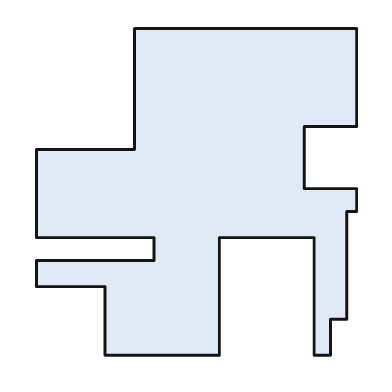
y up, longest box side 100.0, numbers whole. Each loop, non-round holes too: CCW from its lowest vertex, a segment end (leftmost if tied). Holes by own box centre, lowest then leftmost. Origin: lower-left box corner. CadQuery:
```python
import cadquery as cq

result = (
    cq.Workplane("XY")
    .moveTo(21.0, 0.0)
    .lineTo(56.0, 0.0)
    .lineTo(56.0, 36.0)
    .lineTo(85.0, 36.0)
    .lineTo(85.0, 0.0)
    .lineTo(90.0, 0.0)
    .lineTo(90.0, 11.0)
    .lineTo(95.0, 11.0)
    .lineTo(95.0, 44.0)
    .lineTo(98.0, 44.0)
    .lineTo(98.0, 51.0)
    .lineTo(82.0, 51.0)
    .lineTo(82.0, 70.0)
    .lineTo(98.0, 70.0)
    .lineTo(98.0, 100.0)
    .lineTo(30.0, 100.0)
    .lineTo(30.0, 63.0)
    .lineTo(0.0, 63.0)
    .lineTo(0.0, 36.0)
    .lineTo(36.0, 36.0)
    .lineTo(36.0, 29.0)
    .lineTo(0.0, 29.0)
    .lineTo(0.0, 21.0)
    .lineTo(21.0, 21.0)
    .close()
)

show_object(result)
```